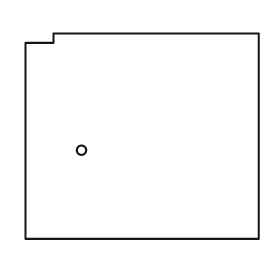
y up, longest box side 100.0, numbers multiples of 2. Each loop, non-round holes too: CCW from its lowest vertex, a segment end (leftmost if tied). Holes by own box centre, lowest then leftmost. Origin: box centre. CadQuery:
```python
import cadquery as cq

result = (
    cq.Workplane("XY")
    .moveTo(-50.0, -44.0)
    .lineTo(50.0, -44.0)
    .lineTo(50.0, 44.0)
    .lineTo(-38.0, 44.0)
    .lineTo(-38.0, 40.0)
    .lineTo(-50.0, 40.0)
    .close()
    .moveTo(-26.0, -6.0)
    .circle(2.0)
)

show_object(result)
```